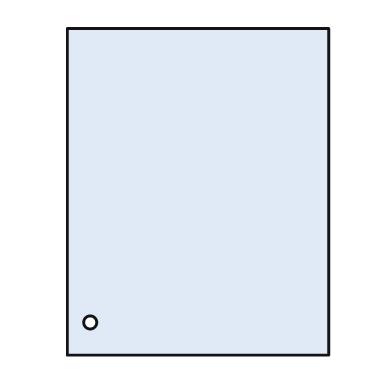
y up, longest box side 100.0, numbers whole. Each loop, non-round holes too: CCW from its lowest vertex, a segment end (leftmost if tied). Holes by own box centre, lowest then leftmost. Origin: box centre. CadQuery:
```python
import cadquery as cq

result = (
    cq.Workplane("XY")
    .moveTo(-40.0, -50.0)
    .lineTo(40.0, -50.0)
    .lineTo(40.0, 50.0)
    .lineTo(-40.0, 50.0)
    .close()
    .moveTo(-33.0, -40.0)
    .circle(2.0)
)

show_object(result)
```